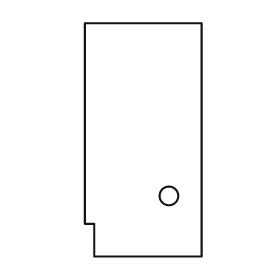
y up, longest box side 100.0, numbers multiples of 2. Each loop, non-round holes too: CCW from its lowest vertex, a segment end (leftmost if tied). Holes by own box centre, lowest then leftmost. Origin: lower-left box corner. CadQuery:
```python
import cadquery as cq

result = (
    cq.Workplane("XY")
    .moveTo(4.0, 0.0)
    .lineTo(50.0, 0.0)
    .lineTo(50.0, 100.0)
    .lineTo(0.0, 100.0)
    .lineTo(0.0, 14.0)
    .lineTo(4.0, 14.0)
    .close()
    .moveTo(36.0, 26.0)
    .circle(4.0)
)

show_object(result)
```